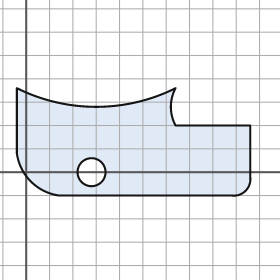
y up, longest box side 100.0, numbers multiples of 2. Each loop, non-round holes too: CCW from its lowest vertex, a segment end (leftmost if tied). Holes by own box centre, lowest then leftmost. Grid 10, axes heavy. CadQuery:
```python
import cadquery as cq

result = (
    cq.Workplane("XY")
    .moveTo(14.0, -10.0)
    .lineTo(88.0, -10.0)
    .threePointArc((94.0, -8.0), (96.0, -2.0))
    .lineTo(96.0, 20.0)
    .lineTo(64.0, 20.0)
    .threePointArc((62.0, 28.0), (64.0, 36.0))
    .threePointArc((30.0, 28.0), (-4.0, 36.0))
    .lineTo(-4.0, 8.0)
    .threePointArc((2.0, -4.0), (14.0, -10.0))
    .close()
    .moveTo(28.0, 0.0)
    .circle(6.0)
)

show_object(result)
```